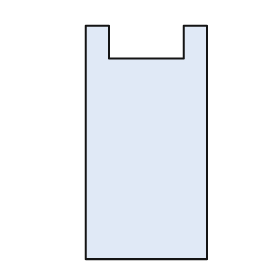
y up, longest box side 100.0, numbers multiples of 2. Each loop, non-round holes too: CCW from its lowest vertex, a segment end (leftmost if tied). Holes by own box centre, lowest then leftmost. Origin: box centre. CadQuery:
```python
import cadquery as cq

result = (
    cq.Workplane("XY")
    .moveTo(-26.0, -50.0)
    .lineTo(26.0, -50.0)
    .lineTo(26.0, 50.0)
    .lineTo(16.0, 50.0)
    .lineTo(16.0, 36.0)
    .lineTo(-16.0, 36.0)
    .lineTo(-16.0, 50.0)
    .lineTo(-26.0, 50.0)
    .close()
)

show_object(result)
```